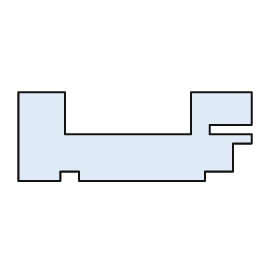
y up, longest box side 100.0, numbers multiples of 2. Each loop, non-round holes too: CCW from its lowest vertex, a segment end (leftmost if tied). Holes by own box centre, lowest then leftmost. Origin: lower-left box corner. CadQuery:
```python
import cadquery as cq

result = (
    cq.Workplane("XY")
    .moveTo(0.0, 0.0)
    .lineTo(18.0, 0.0)
    .lineTo(18.0, 4.0)
    .lineTo(26.0, 4.0)
    .lineTo(26.0, 0.0)
    .lineTo(80.0, 0.0)
    .lineTo(80.0, 4.0)
    .lineTo(92.0, 4.0)
    .lineTo(92.0, 16.0)
    .lineTo(100.0, 16.0)
    .lineTo(100.0, 20.0)
    .lineTo(82.0, 20.0)
    .lineTo(82.0, 24.0)
    .lineTo(100.0, 24.0)
    .lineTo(100.0, 38.0)
    .lineTo(74.0, 38.0)
    .lineTo(74.0, 20.0)
    .lineTo(20.0, 20.0)
    .lineTo(20.0, 38.0)
    .lineTo(0.0, 38.0)
    .close()
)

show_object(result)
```